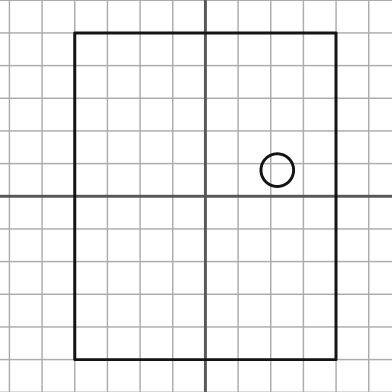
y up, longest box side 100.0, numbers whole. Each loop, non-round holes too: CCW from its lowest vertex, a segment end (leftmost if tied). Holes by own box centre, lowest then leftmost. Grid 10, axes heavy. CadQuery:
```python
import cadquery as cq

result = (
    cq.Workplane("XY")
    .moveTo(-40.0, -50.0)
    .lineTo(40.0, -50.0)
    .lineTo(40.0, 50.0)
    .lineTo(-40.0, 50.0)
    .close()
    .moveTo(22.0, 8.0)
    .circle(5.0)
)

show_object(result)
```